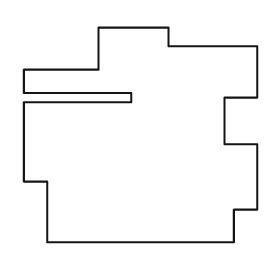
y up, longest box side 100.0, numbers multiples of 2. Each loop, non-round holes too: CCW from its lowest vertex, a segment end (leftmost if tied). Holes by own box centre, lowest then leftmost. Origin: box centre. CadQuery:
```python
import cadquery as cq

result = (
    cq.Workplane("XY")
    .moveTo(-40.0, -46.0)
    .lineTo(40.0, -46.0)
    .lineTo(40.0, -32.0)
    .lineTo(50.0, -32.0)
    .lineTo(50.0, -4.0)
    .lineTo(36.0, -4.0)
    .lineTo(36.0, 16.0)
    .lineTo(50.0, 16.0)
    .lineTo(50.0, 38.0)
    .lineTo(12.0, 38.0)
    .lineTo(12.0, 46.0)
    .lineTo(-18.0, 46.0)
    .lineTo(-18.0, 28.0)
    .lineTo(-50.0, 28.0)
    .lineTo(-50.0, 18.0)
    .lineTo(-4.0, 18.0)
    .lineTo(-4.0, 14.0)
    .lineTo(-50.0, 14.0)
    .lineTo(-50.0, -20.0)
    .lineTo(-40.0, -20.0)
    .close()
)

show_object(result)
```